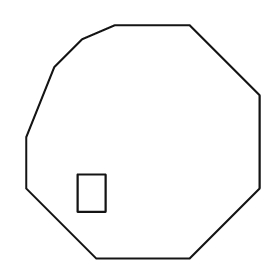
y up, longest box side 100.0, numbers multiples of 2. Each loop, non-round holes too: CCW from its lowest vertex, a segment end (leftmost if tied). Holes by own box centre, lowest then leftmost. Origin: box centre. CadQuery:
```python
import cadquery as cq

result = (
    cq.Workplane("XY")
    .moveTo(-20.0, -50.0)
    .lineTo(20.0, -50.0)
    .lineTo(50.0, -20.0)
    .lineTo(50.0, 20.0)
    .lineTo(20.0, 50.0)
    .lineTo(-12.0, 50.0)
    .lineTo(-26.0, 44.0)
    .lineTo(-38.0, 32.0)
    .lineTo(-50.0, 2.0)
    .lineTo(-50.0, -20.0)
    .close()
    .moveTo(-28.0, -30.0)
    .lineTo(-16.0, -30.0)
    .lineTo(-16.0, -14.0)
    .lineTo(-28.0, -14.0)
    .close()
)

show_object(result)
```